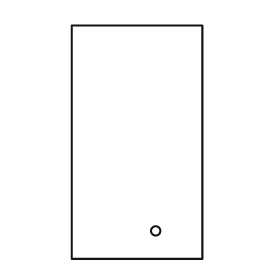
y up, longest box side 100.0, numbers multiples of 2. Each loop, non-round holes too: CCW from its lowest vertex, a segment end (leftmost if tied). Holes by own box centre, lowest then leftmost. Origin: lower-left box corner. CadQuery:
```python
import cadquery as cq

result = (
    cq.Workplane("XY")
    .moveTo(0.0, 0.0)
    .lineTo(56.0, 0.0)
    .lineTo(56.0, 100.0)
    .lineTo(0.0, 100.0)
    .close()
    .moveTo(36.0, 12.0)
    .circle(2.0)
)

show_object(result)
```